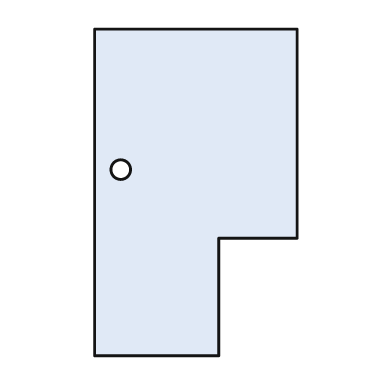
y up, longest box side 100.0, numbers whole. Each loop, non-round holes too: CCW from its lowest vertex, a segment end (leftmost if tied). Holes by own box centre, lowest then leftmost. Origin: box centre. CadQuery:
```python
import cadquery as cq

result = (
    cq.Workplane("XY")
    .moveTo(-31.0, -50.0)
    .lineTo(7.0, -50.0)
    .lineTo(7.0, -14.0)
    .lineTo(31.0, -14.0)
    .lineTo(31.0, 50.0)
    .lineTo(-31.0, 50.0)
    .close()
    .moveTo(-23.0, 7.0)
    .circle(3.0)
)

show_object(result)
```